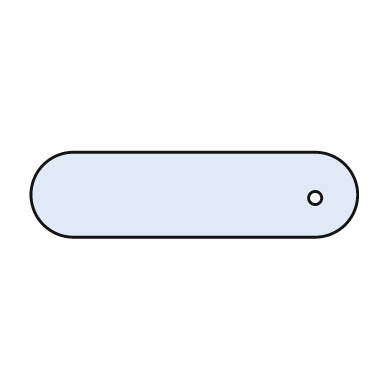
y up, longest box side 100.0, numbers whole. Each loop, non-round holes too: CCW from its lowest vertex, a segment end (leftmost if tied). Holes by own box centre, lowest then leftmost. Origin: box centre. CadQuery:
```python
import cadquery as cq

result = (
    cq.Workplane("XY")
    .moveTo(-37.0, -13.0)
    .lineTo(37.0, -13.0)
    .threePointArc((50.0, 0.0), (37.0, 13.0))
    .lineTo(-37.0, 13.0)
    .threePointArc((-50.0, 0.0), (-37.0, -13.0))
    .close()
    .moveTo(37.0, -1.0)
    .circle(2.0)
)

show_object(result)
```